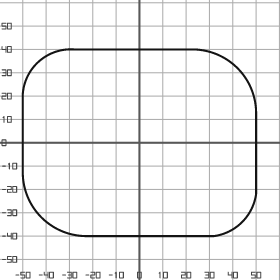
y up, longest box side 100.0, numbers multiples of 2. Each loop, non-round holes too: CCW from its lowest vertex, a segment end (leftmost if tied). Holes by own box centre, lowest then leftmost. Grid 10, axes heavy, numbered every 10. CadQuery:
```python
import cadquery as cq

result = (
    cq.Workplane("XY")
    .moveTo(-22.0, -40.0)
    .lineTo(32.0, -40.0)
    .threePointArc((44.0, -34.0), (50.0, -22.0))
    .lineTo(50.0, 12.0)
    .threePointArc((42.0, 32.0), (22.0, 40.0))
    .lineTo(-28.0, 40.0)
    .threePointArc((-44.0, 34.0), (-50.0, 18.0))
    .lineTo(-50.0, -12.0)
    .threePointArc((-42.0, -32.0), (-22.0, -40.0))
    .close()
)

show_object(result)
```